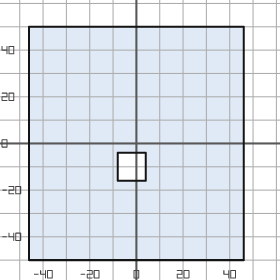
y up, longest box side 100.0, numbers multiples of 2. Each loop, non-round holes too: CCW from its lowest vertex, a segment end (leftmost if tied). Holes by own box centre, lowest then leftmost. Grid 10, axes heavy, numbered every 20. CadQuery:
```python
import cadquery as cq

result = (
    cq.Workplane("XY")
    .moveTo(-46.0, -50.0)
    .lineTo(46.0, -50.0)
    .lineTo(46.0, 50.0)
    .lineTo(-46.0, 50.0)
    .close()
    .moveTo(-8.0, -16.0)
    .lineTo(4.0, -16.0)
    .lineTo(4.0, -4.0)
    .lineTo(-8.0, -4.0)
    .close()
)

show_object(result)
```